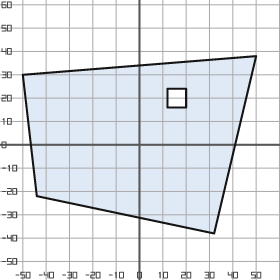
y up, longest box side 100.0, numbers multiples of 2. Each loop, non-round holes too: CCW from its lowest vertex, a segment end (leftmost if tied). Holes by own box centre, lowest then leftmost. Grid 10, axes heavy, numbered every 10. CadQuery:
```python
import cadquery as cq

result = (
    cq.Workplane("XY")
    .moveTo(32.0, -38.0)
    .lineTo(50.0, 38.0)
    .lineTo(-50.0, 30.0)
    .lineTo(-44.0, -22.0)
    .close()
    .moveTo(12.0, 16.0)
    .lineTo(20.0, 16.0)
    .lineTo(20.0, 24.0)
    .lineTo(12.0, 24.0)
    .close()
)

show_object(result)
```